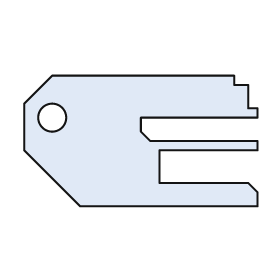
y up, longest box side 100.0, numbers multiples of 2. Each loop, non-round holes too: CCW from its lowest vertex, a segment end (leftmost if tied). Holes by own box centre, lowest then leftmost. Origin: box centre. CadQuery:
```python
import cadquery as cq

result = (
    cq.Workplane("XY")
    .moveTo(-26.0, -28.0)
    .lineTo(50.0, -28.0)
    .lineTo(50.0, -22.0)
    .lineTo(46.0, -18.0)
    .lineTo(8.0, -18.0)
    .lineTo(8.0, -4.0)
    .lineTo(50.0, -4.0)
    .lineTo(50.0, 0.0)
    .lineTo(4.0, 0.0)
    .lineTo(0.0, 4.0)
    .lineTo(0.0, 10.0)
    .lineTo(50.0, 10.0)
    .lineTo(50.0, 14.0)
    .lineTo(46.0, 14.0)
    .lineTo(46.0, 24.0)
    .lineTo(40.0, 24.0)
    .lineTo(40.0, 28.0)
    .lineTo(-38.0, 28.0)
    .lineTo(-50.0, 16.0)
    .lineTo(-50.0, -4.0)
    .close()
    .moveTo(-38.0, 10.0)
    .circle(6.0)
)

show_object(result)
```